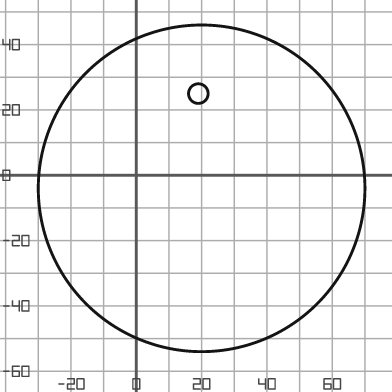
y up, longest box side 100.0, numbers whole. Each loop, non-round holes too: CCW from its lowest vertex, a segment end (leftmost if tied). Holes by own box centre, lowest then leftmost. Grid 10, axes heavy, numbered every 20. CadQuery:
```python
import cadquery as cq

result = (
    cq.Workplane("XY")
    .moveTo(20.0, -4.0)
    .circle(50.0)
    .moveTo(19.0, 25.0)
    .circle(3.0)
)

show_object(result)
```